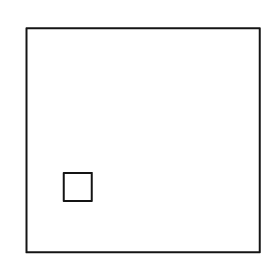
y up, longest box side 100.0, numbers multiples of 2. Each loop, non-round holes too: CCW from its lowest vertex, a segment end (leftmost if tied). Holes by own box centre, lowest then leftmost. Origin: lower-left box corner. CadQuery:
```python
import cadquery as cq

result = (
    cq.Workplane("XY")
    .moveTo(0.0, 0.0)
    .lineTo(100.0, 0.0)
    .lineTo(100.0, 96.0)
    .lineTo(0.0, 96.0)
    .close()
    .moveTo(16.0, 22.0)
    .lineTo(28.0, 22.0)
    .lineTo(28.0, 34.0)
    .lineTo(16.0, 34.0)
    .close()
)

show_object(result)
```